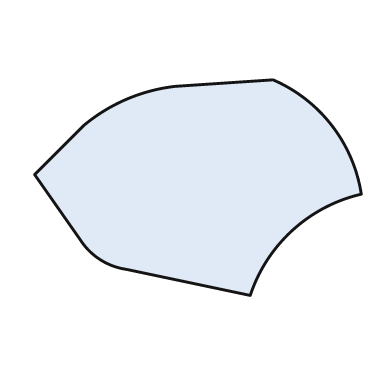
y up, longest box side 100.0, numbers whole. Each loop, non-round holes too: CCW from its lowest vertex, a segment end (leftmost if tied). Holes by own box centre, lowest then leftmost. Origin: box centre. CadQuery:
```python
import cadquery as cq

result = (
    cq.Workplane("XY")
    .moveTo(16.0, -33.0)
    .threePointArc((29.0, -13.0), (50.0, -2.0))
    .threePointArc((41.0, 19.0), (23.0, 33.0))
    .lineTo(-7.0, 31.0)
    .threePointArc((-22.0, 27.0), (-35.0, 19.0))
    .lineTo(-50.0, 4.0)
    .lineTo(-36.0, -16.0)
    .threePointArc((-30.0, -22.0), (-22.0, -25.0))
    .close()
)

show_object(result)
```